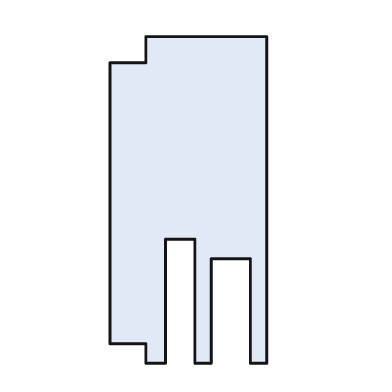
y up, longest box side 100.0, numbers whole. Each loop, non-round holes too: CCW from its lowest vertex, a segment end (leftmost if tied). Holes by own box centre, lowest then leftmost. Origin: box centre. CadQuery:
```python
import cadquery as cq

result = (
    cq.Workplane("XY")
    .moveTo(-13.0, -50.0)
    .lineTo(-7.0, -50.0)
    .lineTo(-7.0, -12.0)
    .lineTo(2.0, -12.0)
    .lineTo(2.0, -50.0)
    .lineTo(7.0, -50.0)
    .lineTo(7.0, -18.0)
    .lineTo(19.0, -18.0)
    .lineTo(19.0, -50.0)
    .lineTo(24.0, -50.0)
    .lineTo(24.0, 50.0)
    .lineTo(-13.0, 50.0)
    .lineTo(-13.0, 42.0)
    .lineTo(-24.0, 42.0)
    .lineTo(-24.0, -44.0)
    .lineTo(-13.0, -44.0)
    .close()
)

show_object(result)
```